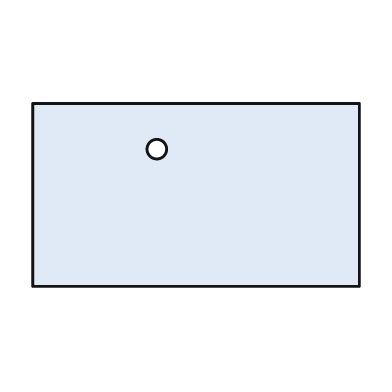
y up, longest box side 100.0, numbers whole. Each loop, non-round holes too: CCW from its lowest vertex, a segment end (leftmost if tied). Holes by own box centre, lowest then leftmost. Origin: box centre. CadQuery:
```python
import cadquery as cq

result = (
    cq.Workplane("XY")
    .moveTo(-50.0, -28.0)
    .lineTo(50.0, -28.0)
    .lineTo(50.0, 28.0)
    .lineTo(-50.0, 28.0)
    .close()
    .moveTo(-12.0, 14.0)
    .circle(3.0)
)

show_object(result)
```